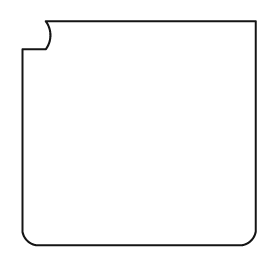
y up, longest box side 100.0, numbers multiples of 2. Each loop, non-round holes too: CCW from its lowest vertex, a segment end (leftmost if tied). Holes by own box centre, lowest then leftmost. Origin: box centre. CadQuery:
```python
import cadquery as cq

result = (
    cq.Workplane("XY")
    .moveTo(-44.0, -48.0)
    .lineTo(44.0, -48.0)
    .threePointArc((48.0, -46.0), (50.0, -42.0))
    .lineTo(50.0, 48.0)
    .lineTo(-40.0, 48.0)
    .threePointArc((-38.0, 42.0), (-40.0, 36.0))
    .lineTo(-50.0, 36.0)
    .lineTo(-50.0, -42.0)
    .threePointArc((-48.0, -46.0), (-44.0, -48.0))
    .close()
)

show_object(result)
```